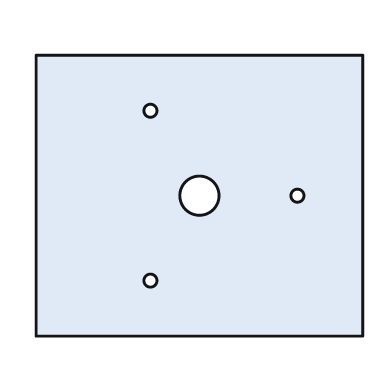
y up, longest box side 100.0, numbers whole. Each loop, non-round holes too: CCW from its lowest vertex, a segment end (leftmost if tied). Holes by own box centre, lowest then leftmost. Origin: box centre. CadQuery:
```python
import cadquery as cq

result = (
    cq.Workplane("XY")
    .moveTo(-50.0, -43.0)
    .lineTo(50.0, -43.0)
    .lineTo(50.0, 43.0)
    .lineTo(-50.0, 43.0)
    .close()
    .moveTo(-15.0, -26.0)
    .circle(2.0)
    .moveTo(0.0, 0.0)
    .circle(6.0)
    .moveTo(30.0, 0.0)
    .circle(2.0)
    .moveTo(-15.0, 26.0)
    .circle(2.0)
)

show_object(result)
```